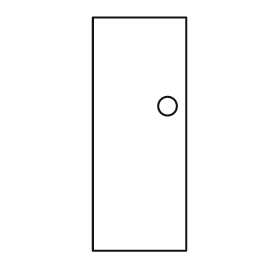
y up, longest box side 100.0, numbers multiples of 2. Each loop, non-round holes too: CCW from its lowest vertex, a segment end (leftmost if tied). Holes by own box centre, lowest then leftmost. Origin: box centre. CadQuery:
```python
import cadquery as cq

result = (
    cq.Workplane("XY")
    .moveTo(-20.0, -50.0)
    .lineTo(20.0, -50.0)
    .lineTo(20.0, 50.0)
    .lineTo(-20.0, 50.0)
    .close()
    .moveTo(12.0, 12.0)
    .circle(4.0)
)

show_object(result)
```